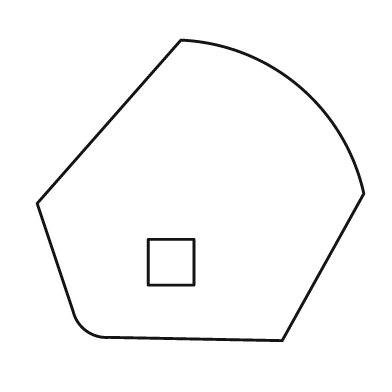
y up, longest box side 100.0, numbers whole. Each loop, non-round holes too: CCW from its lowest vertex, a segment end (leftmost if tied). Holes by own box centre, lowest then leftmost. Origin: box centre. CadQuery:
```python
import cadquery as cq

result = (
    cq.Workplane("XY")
    .moveTo(25.0, -46.0)
    .lineTo(50.0, -1.0)
    .threePointArc((30.0, 32.0), (-6.0, 46.0))
    .lineTo(-50.0, -4.0)
    .lineTo(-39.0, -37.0)
    .threePointArc((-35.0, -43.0), (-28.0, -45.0))
    .close()
    .moveTo(-16.0, -29.0)
    .lineTo(-2.0, -29.0)
    .lineTo(-2.0, -15.0)
    .lineTo(-16.0, -15.0)
    .close()
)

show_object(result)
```